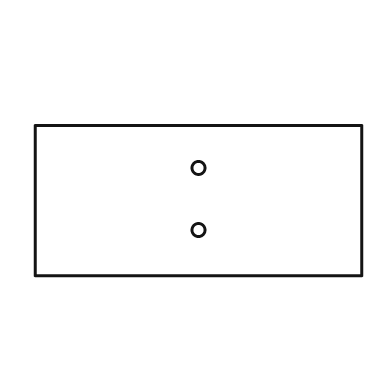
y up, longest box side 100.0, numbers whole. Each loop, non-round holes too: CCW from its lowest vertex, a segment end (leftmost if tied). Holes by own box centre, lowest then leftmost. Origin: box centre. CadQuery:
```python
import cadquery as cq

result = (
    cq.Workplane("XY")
    .moveTo(-50.0, -23.0)
    .lineTo(50.0, -23.0)
    .lineTo(50.0, 23.0)
    .lineTo(-50.0, 23.0)
    .close()
    .moveTo(0.0, -9.0)
    .circle(2.0)
    .moveTo(0.0, 10.0)
    .circle(2.0)
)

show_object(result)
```